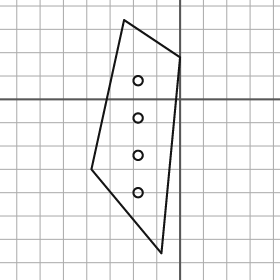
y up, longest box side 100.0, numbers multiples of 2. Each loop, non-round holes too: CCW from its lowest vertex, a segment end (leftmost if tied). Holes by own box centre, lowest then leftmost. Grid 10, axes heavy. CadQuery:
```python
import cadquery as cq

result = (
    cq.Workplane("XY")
    .moveTo(-8.0, -66.0)
    .lineTo(0.0, 18.0)
    .lineTo(-24.0, 34.0)
    .lineTo(-38.0, -30.0)
    .close()
    .moveTo(-18.0, -40.0)
    .circle(2.0)
    .moveTo(-18.0, -24.0)
    .circle(2.0)
    .moveTo(-18.0, -8.0)
    .circle(2.0)
    .moveTo(-18.0, 8.0)
    .circle(2.0)
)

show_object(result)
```